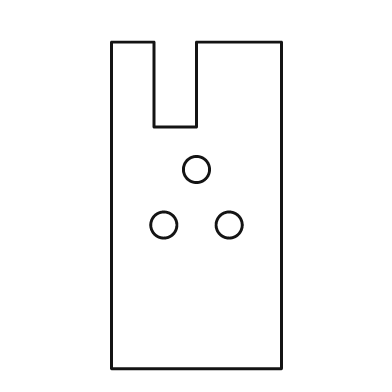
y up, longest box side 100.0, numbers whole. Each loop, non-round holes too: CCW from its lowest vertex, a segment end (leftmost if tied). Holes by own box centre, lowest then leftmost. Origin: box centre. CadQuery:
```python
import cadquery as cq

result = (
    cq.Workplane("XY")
    .moveTo(-26.0, -50.0)
    .lineTo(26.0, -50.0)
    .lineTo(26.0, 50.0)
    .lineTo(0.0, 50.0)
    .lineTo(0.0, 24.0)
    .lineTo(-13.0, 24.0)
    .lineTo(-13.0, 50.0)
    .lineTo(-26.0, 50.0)
    .close()
    .moveTo(-10.0, -6.0)
    .circle(4.0)
    .moveTo(10.0, -6.0)
    .circle(4.0)
    .moveTo(0.0, 11.0)
    .circle(4.0)
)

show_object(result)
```